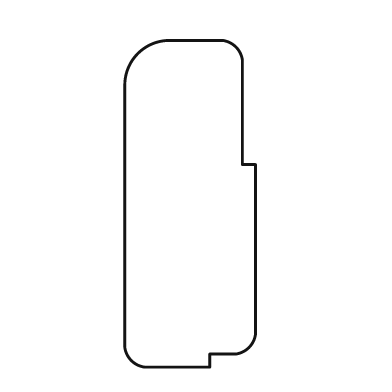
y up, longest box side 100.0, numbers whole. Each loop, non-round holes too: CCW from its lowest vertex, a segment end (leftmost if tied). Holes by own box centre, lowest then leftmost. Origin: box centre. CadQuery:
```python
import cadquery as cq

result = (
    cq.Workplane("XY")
    .moveTo(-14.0, -50.0)
    .lineTo(6.0, -50.0)
    .lineTo(6.0, -46.0)
    .lineTo(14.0, -46.0)
    .threePointArc((18.0, -44.0), (20.0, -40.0))
    .lineTo(20.0, 12.0)
    .lineTo(16.0, 12.0)
    .lineTo(16.0, 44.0)
    .threePointArc((14.0, 48.0), (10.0, 50.0))
    .lineTo(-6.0, 50.0)
    .threePointArc((-16.0, 46.0), (-20.0, 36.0))
    .lineTo(-20.0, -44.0)
    .threePointArc((-18.0, -48.0), (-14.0, -50.0))
    .close()
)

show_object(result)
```